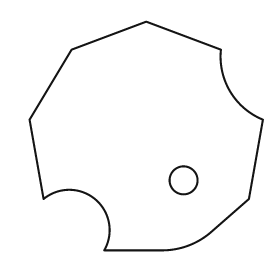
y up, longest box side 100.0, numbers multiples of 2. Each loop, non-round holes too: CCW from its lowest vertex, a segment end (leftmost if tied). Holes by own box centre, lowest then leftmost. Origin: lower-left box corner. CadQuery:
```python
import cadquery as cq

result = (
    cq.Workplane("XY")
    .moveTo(32.0, 0.0)
    .lineTo(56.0, 0.0)
    .threePointArc((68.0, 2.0), (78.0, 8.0))
    .lineTo(94.0, 22.0)
    .lineTo(100.0, 56.0)
    .threePointArc((86.0, 68.0), (82.0, 86.0))
    .lineTo(50.0, 98.0)
    .lineTo(18.0, 86.0)
    .lineTo(0.0, 56.0)
    .lineTo(6.0, 22.0)
    .threePointArc((28.0, 22.0), (32.0, 0.0))
    .close()
    .moveTo(66.0, 30.0)
    .circle(6.0)
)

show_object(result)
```